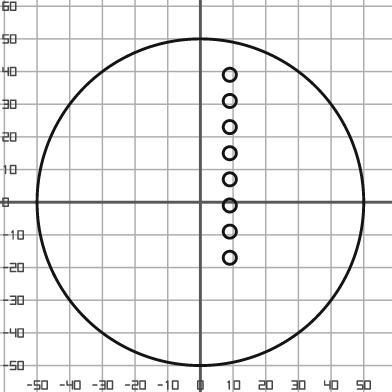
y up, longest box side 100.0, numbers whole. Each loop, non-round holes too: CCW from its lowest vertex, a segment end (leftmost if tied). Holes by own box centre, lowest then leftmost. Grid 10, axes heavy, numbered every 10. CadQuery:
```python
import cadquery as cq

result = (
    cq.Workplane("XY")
    .moveTo(0.0, 0.0)
    .circle(50.0)
    .moveTo(9.0, -17.0)
    .circle(2.0)
    .moveTo(9.0, -9.0)
    .circle(2.0)
    .moveTo(9.0, -1.0)
    .circle(2.0)
    .moveTo(9.0, 7.0)
    .circle(2.0)
    .moveTo(9.0, 15.0)
    .circle(2.0)
    .moveTo(9.0, 23.0)
    .circle(2.0)
    .moveTo(9.0, 31.0)
    .circle(2.0)
    .moveTo(9.0, 39.0)
    .circle(2.0)
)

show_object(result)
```